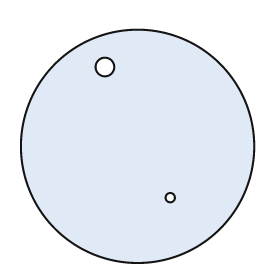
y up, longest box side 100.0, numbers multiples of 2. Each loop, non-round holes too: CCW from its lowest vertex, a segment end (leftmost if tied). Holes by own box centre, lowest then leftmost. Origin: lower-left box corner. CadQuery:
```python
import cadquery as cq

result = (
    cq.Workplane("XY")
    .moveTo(50.0, 50.0)
    .circle(50.0)
    .moveTo(64.0, 28.0)
    .circle(2.0)
    .moveTo(36.0, 84.0)
    .circle(4.0)
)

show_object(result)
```